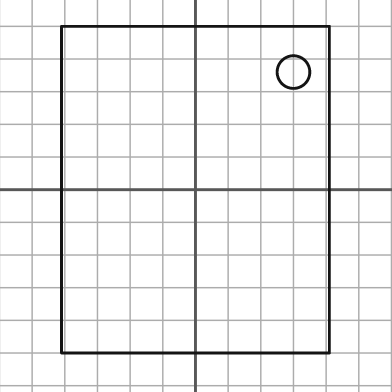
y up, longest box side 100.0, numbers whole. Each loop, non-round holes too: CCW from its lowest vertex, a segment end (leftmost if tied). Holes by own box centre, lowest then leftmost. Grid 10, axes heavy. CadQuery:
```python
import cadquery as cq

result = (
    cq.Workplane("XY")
    .moveTo(-41.0, -50.0)
    .lineTo(41.0, -50.0)
    .lineTo(41.0, 50.0)
    .lineTo(-41.0, 50.0)
    .close()
    .moveTo(30.0, 36.0)
    .circle(5.0)
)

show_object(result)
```